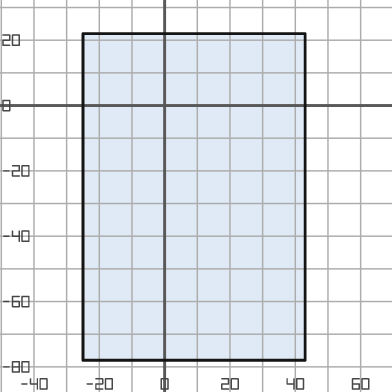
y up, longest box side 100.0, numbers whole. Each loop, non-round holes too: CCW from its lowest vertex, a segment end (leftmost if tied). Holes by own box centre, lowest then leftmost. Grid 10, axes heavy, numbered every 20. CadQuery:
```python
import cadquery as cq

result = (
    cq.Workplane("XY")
    .moveTo(-25.0, -78.0)
    .lineTo(43.0, -78.0)
    .lineTo(43.0, 22.0)
    .lineTo(-25.0, 22.0)
    .close()
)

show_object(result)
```